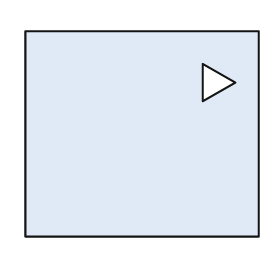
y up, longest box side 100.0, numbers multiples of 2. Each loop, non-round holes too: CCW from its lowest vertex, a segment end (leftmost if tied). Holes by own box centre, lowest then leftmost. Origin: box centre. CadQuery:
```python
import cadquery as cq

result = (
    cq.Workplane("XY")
    .moveTo(-50.0, -44.0)
    .lineTo(50.0, -44.0)
    .lineTo(50.0, 44.0)
    .lineTo(-50.0, 44.0)
    .close()
    .moveTo(26.0, 14.0)
    .lineTo(40.0, 22.0)
    .lineTo(26.0, 30.0)
    .close()
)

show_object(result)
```